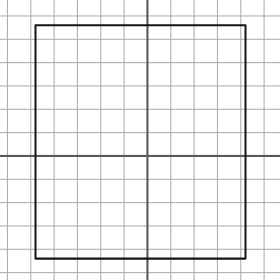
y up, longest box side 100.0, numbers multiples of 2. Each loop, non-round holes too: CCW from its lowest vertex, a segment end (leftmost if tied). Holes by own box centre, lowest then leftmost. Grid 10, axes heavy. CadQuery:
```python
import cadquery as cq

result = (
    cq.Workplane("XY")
    .moveTo(-48.0, -44.0)
    .lineTo(42.0, -44.0)
    .lineTo(42.0, 56.0)
    .lineTo(-48.0, 56.0)
    .close()
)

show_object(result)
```